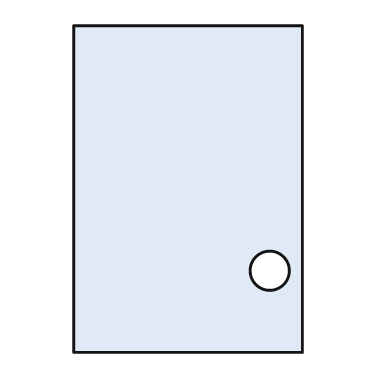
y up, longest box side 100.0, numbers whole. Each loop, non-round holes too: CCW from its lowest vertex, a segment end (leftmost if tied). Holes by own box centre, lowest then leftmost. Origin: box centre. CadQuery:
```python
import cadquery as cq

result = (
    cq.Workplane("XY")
    .moveTo(-35.0, -50.0)
    .lineTo(35.0, -50.0)
    .lineTo(35.0, 50.0)
    .lineTo(-35.0, 50.0)
    .close()
    .moveTo(25.0, -25.0)
    .circle(6.0)
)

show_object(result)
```